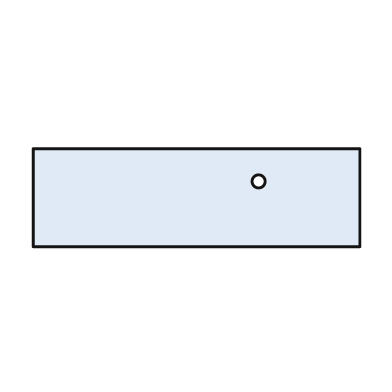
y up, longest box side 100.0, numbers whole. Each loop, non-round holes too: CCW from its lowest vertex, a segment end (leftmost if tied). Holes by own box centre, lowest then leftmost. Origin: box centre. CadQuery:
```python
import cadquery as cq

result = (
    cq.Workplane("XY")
    .moveTo(-50.0, -15.0)
    .lineTo(50.0, -15.0)
    .lineTo(50.0, 15.0)
    .lineTo(-50.0, 15.0)
    .close()
    .moveTo(19.0, 5.0)
    .circle(2.0)
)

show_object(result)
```